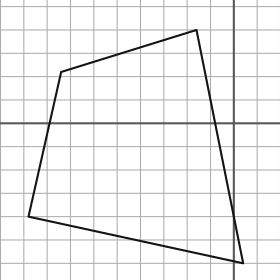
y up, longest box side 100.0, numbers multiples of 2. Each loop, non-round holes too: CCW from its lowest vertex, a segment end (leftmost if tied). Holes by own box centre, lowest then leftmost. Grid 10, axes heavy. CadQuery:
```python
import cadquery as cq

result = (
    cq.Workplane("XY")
    .moveTo(4.0, -60.0)
    .lineTo(-16.0, 40.0)
    .lineTo(-74.0, 22.0)
    .lineTo(-88.0, -40.0)
    .close()
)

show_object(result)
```